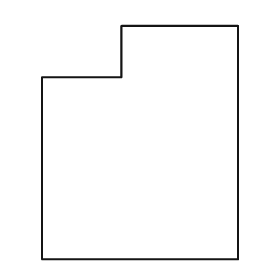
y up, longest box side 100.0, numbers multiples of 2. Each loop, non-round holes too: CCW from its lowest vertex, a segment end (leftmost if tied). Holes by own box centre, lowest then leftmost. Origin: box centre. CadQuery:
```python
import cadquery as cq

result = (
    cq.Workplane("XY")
    .moveTo(-42.0, -50.0)
    .lineTo(42.0, -50.0)
    .lineTo(42.0, 50.0)
    .lineTo(-8.0, 50.0)
    .lineTo(-8.0, 28.0)
    .lineTo(-42.0, 28.0)
    .close()
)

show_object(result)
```